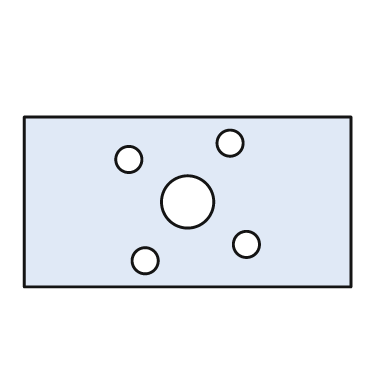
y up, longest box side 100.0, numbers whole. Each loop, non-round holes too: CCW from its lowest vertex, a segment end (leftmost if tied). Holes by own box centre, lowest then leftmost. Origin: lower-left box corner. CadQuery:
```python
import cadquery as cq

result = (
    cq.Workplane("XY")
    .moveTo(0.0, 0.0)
    .lineTo(100.0, 0.0)
    .lineTo(100.0, 52.0)
    .lineTo(0.0, 52.0)
    .close()
    .moveTo(37.0, 8.0)
    .circle(4.0)
    .moveTo(68.0, 13.0)
    .circle(4.0)
    .moveTo(50.0, 26.0)
    .circle(8.0)
    .moveTo(32.0, 39.0)
    .circle(4.0)
    .moveTo(63.0, 44.0)
    .circle(4.0)
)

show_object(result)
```